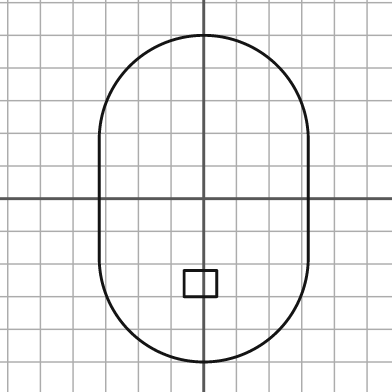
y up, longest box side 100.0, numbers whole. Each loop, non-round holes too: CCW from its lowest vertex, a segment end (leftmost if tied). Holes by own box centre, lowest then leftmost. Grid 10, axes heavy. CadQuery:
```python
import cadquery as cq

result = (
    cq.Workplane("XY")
    .moveTo(-32.0, -18.0)
    .threePointArc((0.0, -50.0), (32.0, -18.0))
    .lineTo(32.0, 18.0)
    .threePointArc((0.0, 50.0), (-32.0, 18.0))
    .close()
    .moveTo(-6.0, -30.0)
    .lineTo(4.0, -30.0)
    .lineTo(4.0, -22.0)
    .lineTo(-6.0, -22.0)
    .close()
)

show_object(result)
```